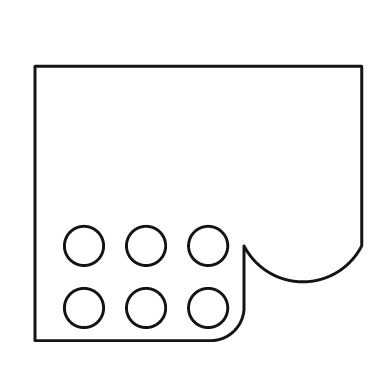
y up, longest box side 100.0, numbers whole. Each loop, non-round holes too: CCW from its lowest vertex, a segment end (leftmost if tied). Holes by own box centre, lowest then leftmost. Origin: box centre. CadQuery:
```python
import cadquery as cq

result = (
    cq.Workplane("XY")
    .moveTo(-50.0, -42.0)
    .lineTo(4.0, -42.0)
    .threePointArc((11.0, -39.0), (14.0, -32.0))
    .lineTo(14.0, -13.0)
    .threePointArc((32.0, -24.0), (50.0, -13.0))
    .lineTo(50.0, 42.0)
    .lineTo(-50.0, 42.0)
    .close()
    .moveTo(-35.0, -32.0)
    .circle(6.0)
    .moveTo(-16.0, -32.0)
    .circle(6.0)
    .moveTo(3.0, -32.0)
    .circle(6.0)
    .moveTo(-35.0, -13.0)
    .circle(6.0)
    .moveTo(-16.0, -13.0)
    .circle(6.0)
    .moveTo(3.0, -13.0)
    .circle(6.0)
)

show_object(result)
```